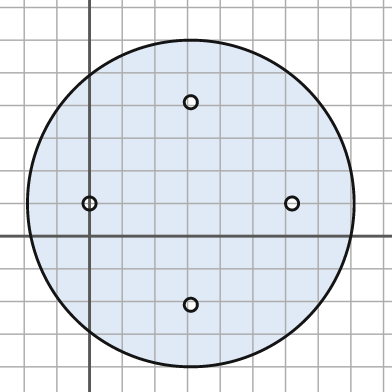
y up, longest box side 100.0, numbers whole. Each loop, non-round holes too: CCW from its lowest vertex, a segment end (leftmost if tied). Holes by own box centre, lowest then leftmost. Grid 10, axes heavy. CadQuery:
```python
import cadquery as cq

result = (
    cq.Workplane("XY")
    .moveTo(31.0, 10.0)
    .circle(50.0)
    .moveTo(31.0, -21.0)
    .circle(2.0)
    .moveTo(0.0, 10.0)
    .circle(2.0)
    .moveTo(62.0, 10.0)
    .circle(2.0)
    .moveTo(31.0, 41.0)
    .circle(2.0)
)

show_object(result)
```